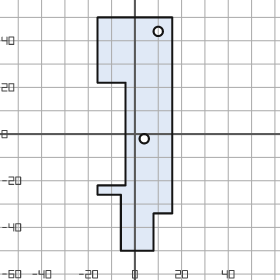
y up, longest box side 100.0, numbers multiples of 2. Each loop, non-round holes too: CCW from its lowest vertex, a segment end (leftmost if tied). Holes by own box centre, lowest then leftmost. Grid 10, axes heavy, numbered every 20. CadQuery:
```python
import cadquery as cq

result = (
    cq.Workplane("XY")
    .moveTo(-6.0, -50.0)
    .lineTo(8.0, -50.0)
    .lineTo(8.0, -34.0)
    .lineTo(16.0, -34.0)
    .lineTo(16.0, 50.0)
    .lineTo(-16.0, 50.0)
    .lineTo(-16.0, 22.0)
    .lineTo(-4.0, 22.0)
    .lineTo(-4.0, -22.0)
    .lineTo(-16.0, -22.0)
    .lineTo(-16.0, -26.0)
    .lineTo(-6.0, -26.0)
    .close()
    .moveTo(4.0, -2.0)
    .circle(2.0)
    .moveTo(10.0, 44.0)
    .circle(2.0)
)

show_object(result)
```